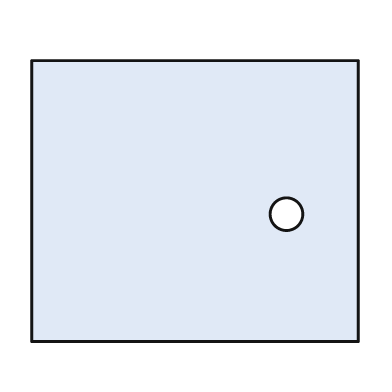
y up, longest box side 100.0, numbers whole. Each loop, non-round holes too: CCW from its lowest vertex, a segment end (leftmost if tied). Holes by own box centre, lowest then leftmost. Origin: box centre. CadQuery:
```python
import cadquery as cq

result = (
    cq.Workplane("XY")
    .moveTo(-50.0, -43.0)
    .lineTo(50.0, -43.0)
    .lineTo(50.0, 43.0)
    .lineTo(-50.0, 43.0)
    .close()
    .moveTo(28.0, -4.0)
    .circle(5.0)
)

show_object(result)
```